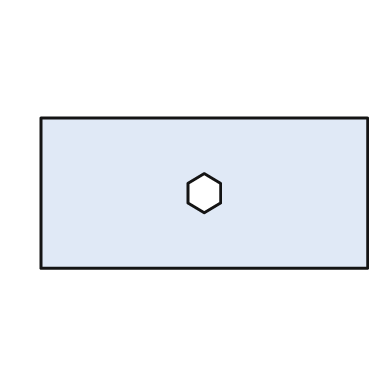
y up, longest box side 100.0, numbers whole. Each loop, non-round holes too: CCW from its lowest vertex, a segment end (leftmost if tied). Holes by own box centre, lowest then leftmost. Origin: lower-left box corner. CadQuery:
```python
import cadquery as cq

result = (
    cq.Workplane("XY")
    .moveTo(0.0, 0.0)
    .lineTo(100.0, 0.0)
    .lineTo(100.0, 46.0)
    .lineTo(0.0, 46.0)
    .close()
    .moveTo(50.0, 17.0)
    .lineTo(55.0, 20.0)
    .lineTo(55.0, 26.0)
    .lineTo(50.0, 29.0)
    .lineTo(45.0, 26.0)
    .lineTo(45.0, 20.0)
    .close()
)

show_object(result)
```